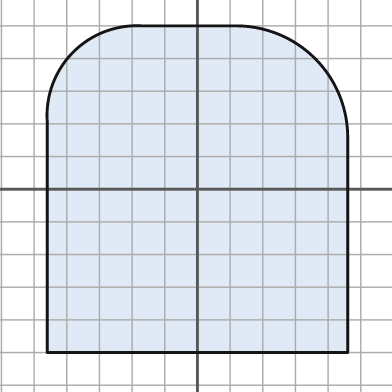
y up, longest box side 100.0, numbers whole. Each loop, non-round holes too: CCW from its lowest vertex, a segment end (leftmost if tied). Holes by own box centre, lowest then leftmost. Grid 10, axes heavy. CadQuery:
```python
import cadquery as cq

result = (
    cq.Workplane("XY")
    .moveTo(-46.0, -50.0)
    .lineTo(46.0, -50.0)
    .lineTo(46.0, 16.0)
    .threePointArc((36.0, 40.0), (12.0, 50.0))
    .lineTo(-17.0, 50.0)
    .threePointArc((-38.0, 42.0), (-46.0, 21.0))
    .close()
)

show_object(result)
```